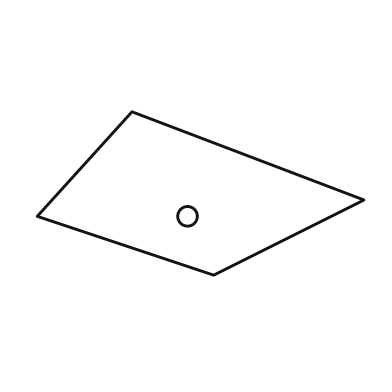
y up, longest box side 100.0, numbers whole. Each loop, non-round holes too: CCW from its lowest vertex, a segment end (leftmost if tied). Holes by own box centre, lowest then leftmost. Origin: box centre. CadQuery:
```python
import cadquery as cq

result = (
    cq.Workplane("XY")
    .moveTo(4.0, -25.0)
    .lineTo(50.0, -2.0)
    .lineTo(-21.0, 25.0)
    .lineTo(-50.0, -7.0)
    .close()
    .moveTo(-4.0, -7.0)
    .circle(3.0)
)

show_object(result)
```